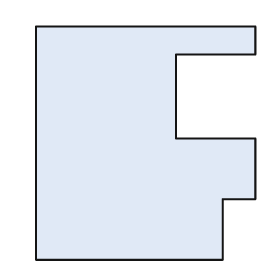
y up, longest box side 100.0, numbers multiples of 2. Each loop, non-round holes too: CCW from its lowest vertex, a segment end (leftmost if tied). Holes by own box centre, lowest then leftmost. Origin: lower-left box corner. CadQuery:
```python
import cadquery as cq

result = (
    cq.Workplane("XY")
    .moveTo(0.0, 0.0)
    .lineTo(80.0, 0.0)
    .lineTo(80.0, 26.0)
    .lineTo(94.0, 26.0)
    .lineTo(94.0, 52.0)
    .lineTo(60.0, 52.0)
    .lineTo(60.0, 88.0)
    .lineTo(94.0, 88.0)
    .lineTo(94.0, 100.0)
    .lineTo(0.0, 100.0)
    .close()
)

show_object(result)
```